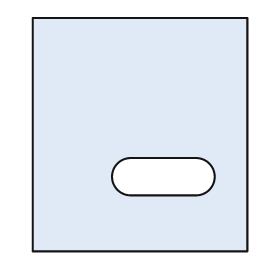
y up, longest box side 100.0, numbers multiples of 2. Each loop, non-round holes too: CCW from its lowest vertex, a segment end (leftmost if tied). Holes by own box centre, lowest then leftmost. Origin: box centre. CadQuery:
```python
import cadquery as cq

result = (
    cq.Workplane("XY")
    .moveTo(-46.0, -50.0)
    .lineTo(46.0, -50.0)
    .lineTo(46.0, 50.0)
    .lineTo(-46.0, 50.0)
    .close()
    .moveTo(-4.0, -26.0)
    .lineTo(24.0, -26.0)
    .threePointArc((32.0, -18.0), (24.0, -10.0))
    .lineTo(-4.0, -10.0)
    .threePointArc((-12.0, -18.0), (-4.0, -26.0))
    .close()
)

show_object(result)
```